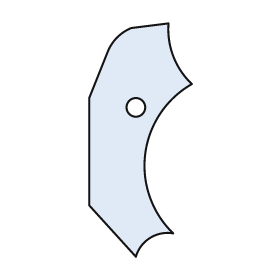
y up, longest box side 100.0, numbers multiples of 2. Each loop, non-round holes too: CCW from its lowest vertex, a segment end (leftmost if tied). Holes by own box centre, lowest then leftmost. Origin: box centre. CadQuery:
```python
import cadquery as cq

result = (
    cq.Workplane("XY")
    .moveTo(-2.0, -50.0)
    .threePointArc((4.0, -42.0), (14.0, -40.0))
    .threePointArc((2.0, -6.0), (22.0, 24.0))
    .threePointArc((14.0, 36.0), (12.0, 50.0))
    .lineTo(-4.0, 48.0)
    .threePointArc((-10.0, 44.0), (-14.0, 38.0))
    .lineTo(-22.0, 18.0)
    .lineTo(-22.0, -28.0)
    .close()
    .moveTo(-2.0, 14.0)
    .circle(4.0)
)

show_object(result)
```